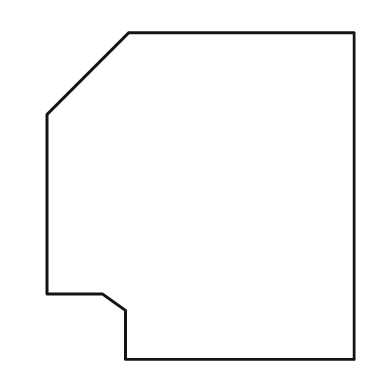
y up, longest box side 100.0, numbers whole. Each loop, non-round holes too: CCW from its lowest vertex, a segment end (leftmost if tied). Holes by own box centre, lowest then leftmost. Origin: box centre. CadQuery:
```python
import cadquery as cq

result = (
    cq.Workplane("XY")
    .moveTo(-23.0, -50.0)
    .lineTo(47.0, -50.0)
    .lineTo(47.0, 50.0)
    .lineTo(-22.0, 50.0)
    .lineTo(-47.0, 25.0)
    .lineTo(-47.0, -30.0)
    .lineTo(-30.0, -30.0)
    .lineTo(-23.0, -35.0)
    .close()
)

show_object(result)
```